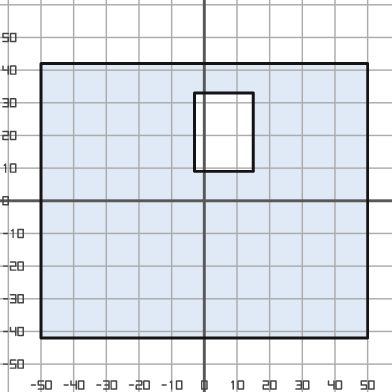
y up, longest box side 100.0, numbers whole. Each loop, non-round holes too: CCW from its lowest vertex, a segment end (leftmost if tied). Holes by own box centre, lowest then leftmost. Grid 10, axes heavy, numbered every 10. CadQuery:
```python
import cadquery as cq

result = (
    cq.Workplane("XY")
    .moveTo(-50.0, -42.0)
    .lineTo(50.0, -42.0)
    .lineTo(50.0, 42.0)
    .lineTo(-50.0, 42.0)
    .close()
    .moveTo(-3.0, 9.0)
    .lineTo(15.0, 9.0)
    .lineTo(15.0, 33.0)
    .lineTo(-3.0, 33.0)
    .close()
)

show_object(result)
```